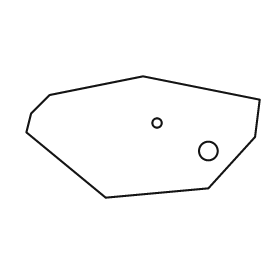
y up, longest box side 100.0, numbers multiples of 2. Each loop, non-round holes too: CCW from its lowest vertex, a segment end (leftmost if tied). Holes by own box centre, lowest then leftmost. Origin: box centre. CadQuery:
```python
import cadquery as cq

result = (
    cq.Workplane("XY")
    .moveTo(-16.0, -26.0)
    .lineTo(28.0, -22.0)
    .lineTo(48.0, 0.0)
    .lineTo(50.0, 16.0)
    .lineTo(0.0, 26.0)
    .lineTo(-40.0, 18.0)
    .lineTo(-48.0, 10.0)
    .lineTo(-50.0, 2.0)
    .close()
    .moveTo(28.0, -6.0)
    .circle(4.0)
    .moveTo(6.0, 6.0)
    .circle(2.0)
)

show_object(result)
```